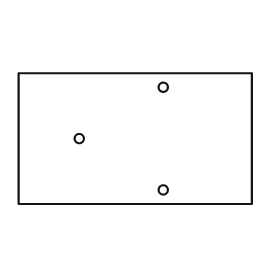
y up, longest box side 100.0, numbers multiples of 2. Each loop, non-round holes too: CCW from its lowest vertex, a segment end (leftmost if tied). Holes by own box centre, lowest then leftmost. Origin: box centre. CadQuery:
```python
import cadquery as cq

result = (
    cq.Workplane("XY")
    .moveTo(-50.0, -28.0)
    .lineTo(50.0, -28.0)
    .lineTo(50.0, 28.0)
    .lineTo(-50.0, 28.0)
    .close()
    .moveTo(12.0, -22.0)
    .circle(2.0)
    .moveTo(-24.0, 0.0)
    .circle(2.0)
    .moveTo(12.0, 22.0)
    .circle(2.0)
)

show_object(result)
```